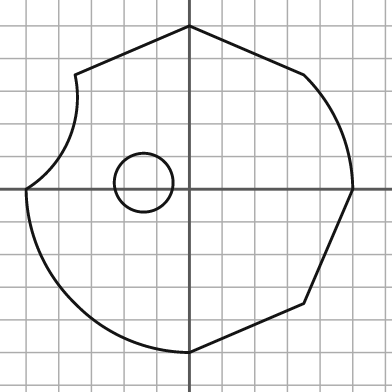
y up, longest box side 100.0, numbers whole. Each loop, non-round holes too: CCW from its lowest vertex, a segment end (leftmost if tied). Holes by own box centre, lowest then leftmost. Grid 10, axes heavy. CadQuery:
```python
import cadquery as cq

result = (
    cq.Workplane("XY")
    .moveTo(0.0, -50.0)
    .lineTo(35.0, -35.0)
    .lineTo(50.0, 0.0)
    .threePointArc((46.0, 19.0), (35.0, 35.0))
    .lineTo(0.0, 50.0)
    .lineTo(-35.0, 35.0)
    .threePointArc((-37.0, 15.0), (-50.0, 0.0))
    .threePointArc((-46.0, -19.0), (-35.0, -35.0))
    .threePointArc((-19.0, -46.0), (0.0, -50.0))
    .close()
    .moveTo(-14.0, 2.0)
    .circle(9.0)
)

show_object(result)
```